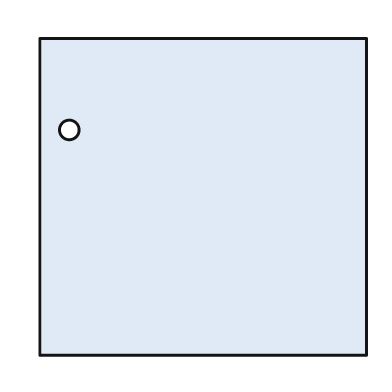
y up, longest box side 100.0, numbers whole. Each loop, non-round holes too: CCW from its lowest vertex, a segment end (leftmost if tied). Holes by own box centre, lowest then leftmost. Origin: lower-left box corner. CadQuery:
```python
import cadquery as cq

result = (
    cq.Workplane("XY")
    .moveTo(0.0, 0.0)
    .lineTo(100.0, 0.0)
    .lineTo(100.0, 97.0)
    .lineTo(0.0, 97.0)
    .close()
    .moveTo(9.0, 69.0)
    .circle(3.0)
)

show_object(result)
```